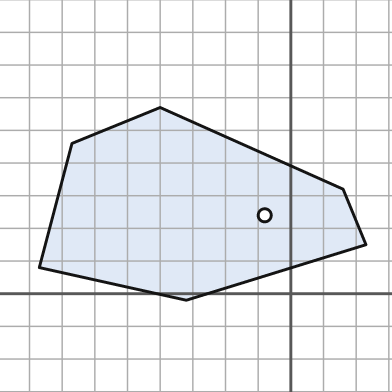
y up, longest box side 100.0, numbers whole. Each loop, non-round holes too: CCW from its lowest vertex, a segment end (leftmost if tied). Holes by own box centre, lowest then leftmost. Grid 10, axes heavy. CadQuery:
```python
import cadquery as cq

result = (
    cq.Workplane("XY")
    .moveTo(-32.0, -2.0)
    .lineTo(23.0, 15.0)
    .lineTo(16.0, 32.0)
    .lineTo(-40.0, 57.0)
    .lineTo(-67.0, 46.0)
    .lineTo(-77.0, 8.0)
    .close()
    .moveTo(-8.0, 24.0)
    .circle(2.0)
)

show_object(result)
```